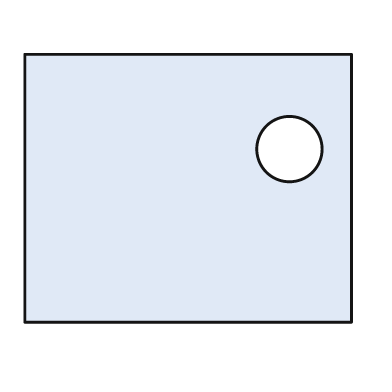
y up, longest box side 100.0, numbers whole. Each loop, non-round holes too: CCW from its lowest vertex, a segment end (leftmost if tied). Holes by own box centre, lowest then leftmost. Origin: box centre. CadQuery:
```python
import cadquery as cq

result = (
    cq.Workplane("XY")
    .moveTo(-50.0, -41.0)
    .lineTo(50.0, -41.0)
    .lineTo(50.0, 41.0)
    .lineTo(-50.0, 41.0)
    .close()
    .moveTo(31.0, 12.0)
    .circle(10.0)
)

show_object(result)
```